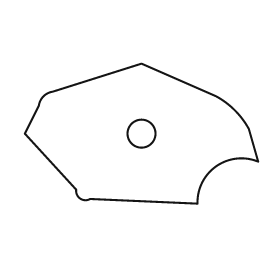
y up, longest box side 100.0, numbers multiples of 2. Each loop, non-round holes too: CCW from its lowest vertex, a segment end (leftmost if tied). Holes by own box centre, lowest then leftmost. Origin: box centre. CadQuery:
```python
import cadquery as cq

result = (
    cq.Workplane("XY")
    .moveTo(24.0, -30.0)
    .threePointArc((32.0, -14.0), (50.0, -12.0))
    .lineTo(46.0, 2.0)
    .threePointArc((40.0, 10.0), (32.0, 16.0))
    .lineTo(0.0, 30.0)
    .lineTo(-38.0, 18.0)
    .threePointArc((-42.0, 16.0), (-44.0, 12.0))
    .lineTo(-50.0, 0.0)
    .lineTo(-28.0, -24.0)
    .threePointArc((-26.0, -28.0), (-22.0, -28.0))
    .close()
    .moveTo(0.0, 0.0)
    .circle(6.0)
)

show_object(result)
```